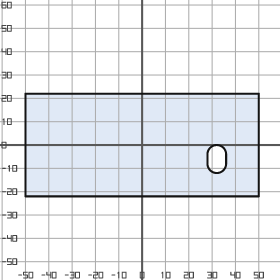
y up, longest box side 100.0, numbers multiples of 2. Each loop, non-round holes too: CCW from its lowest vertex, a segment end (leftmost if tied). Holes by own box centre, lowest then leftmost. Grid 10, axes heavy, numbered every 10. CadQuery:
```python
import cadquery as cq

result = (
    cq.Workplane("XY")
    .moveTo(-50.0, -22.0)
    .lineTo(50.0, -22.0)
    .lineTo(50.0, 22.0)
    .lineTo(-50.0, 22.0)
    .close()
    .moveTo(28.0, -8.0)
    .threePointArc((32.0, -12.0), (36.0, -8.0))
    .lineTo(36.0, -4.0)
    .threePointArc((32.0, 0.0), (28.0, -4.0))
    .close()
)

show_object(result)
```